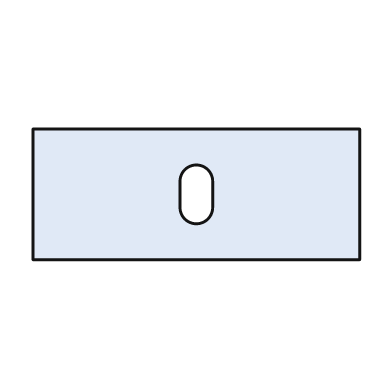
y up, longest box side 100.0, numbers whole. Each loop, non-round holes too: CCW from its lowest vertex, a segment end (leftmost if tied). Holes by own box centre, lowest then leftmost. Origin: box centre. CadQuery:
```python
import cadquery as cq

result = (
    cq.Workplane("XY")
    .moveTo(-50.0, -20.0)
    .lineTo(50.0, -20.0)
    .lineTo(50.0, 20.0)
    .lineTo(-50.0, 20.0)
    .close()
    .moveTo(-5.0, -4.0)
    .threePointArc((0.0, -9.0), (5.0, -4.0))
    .lineTo(5.0, 4.0)
    .threePointArc((0.0, 9.0), (-5.0, 4.0))
    .close()
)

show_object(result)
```